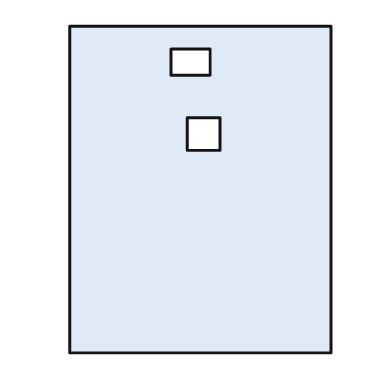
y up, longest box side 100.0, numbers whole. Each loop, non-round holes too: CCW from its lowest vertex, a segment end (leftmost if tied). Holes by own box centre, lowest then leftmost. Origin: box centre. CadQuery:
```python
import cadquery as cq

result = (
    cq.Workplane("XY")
    .moveTo(-40.0, -50.0)
    .lineTo(40.0, -50.0)
    .lineTo(40.0, 50.0)
    .lineTo(-40.0, 50.0)
    .close()
    .moveTo(-4.0, 12.0)
    .lineTo(6.0, 12.0)
    .lineTo(6.0, 22.0)
    .lineTo(-4.0, 22.0)
    .close()
    .moveTo(-9.0, 35.0)
    .lineTo(3.0, 35.0)
    .lineTo(3.0, 43.0)
    .lineTo(-9.0, 43.0)
    .close()
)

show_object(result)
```